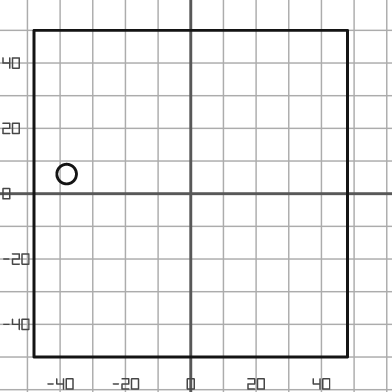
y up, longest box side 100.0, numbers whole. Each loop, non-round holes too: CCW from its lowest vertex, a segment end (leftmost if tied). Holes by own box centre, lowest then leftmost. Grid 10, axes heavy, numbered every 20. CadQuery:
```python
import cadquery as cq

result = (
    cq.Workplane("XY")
    .moveTo(-48.0, -50.0)
    .lineTo(48.0, -50.0)
    .lineTo(48.0, 50.0)
    .lineTo(-48.0, 50.0)
    .close()
    .moveTo(-38.0, 6.0)
    .circle(3.0)
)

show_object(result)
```